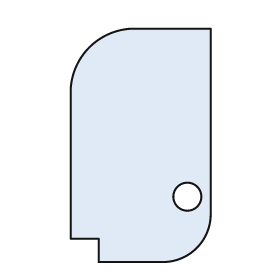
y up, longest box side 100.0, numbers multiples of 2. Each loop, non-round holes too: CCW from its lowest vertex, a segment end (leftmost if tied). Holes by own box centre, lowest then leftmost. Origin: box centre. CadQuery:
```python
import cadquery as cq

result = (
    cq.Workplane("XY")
    .moveTo(-18.0, -50.0)
    .lineTo(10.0, -50.0)
    .threePointArc((24.0, -44.0), (30.0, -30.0))
    .lineTo(30.0, 50.0)
    .lineTo(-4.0, 50.0)
    .threePointArc((-22.0, 42.0), (-30.0, 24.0))
    .lineTo(-30.0, -40.0)
    .lineTo(-18.0, -40.0)
    .close()
    .moveTo(20.0, -22.0)
    .circle(6.0)
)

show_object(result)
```